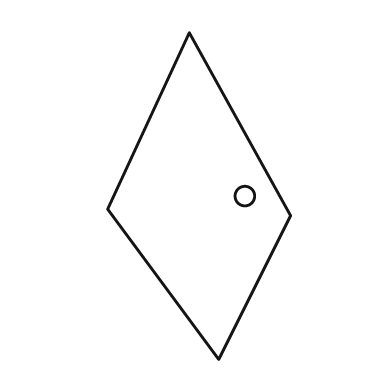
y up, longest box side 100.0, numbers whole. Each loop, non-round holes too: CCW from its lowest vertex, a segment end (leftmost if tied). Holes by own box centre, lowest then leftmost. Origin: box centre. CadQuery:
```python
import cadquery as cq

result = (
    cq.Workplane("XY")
    .moveTo(6.0, -50.0)
    .lineTo(28.0, -6.0)
    .lineTo(-3.0, 50.0)
    .lineTo(-28.0, -4.0)
    .close()
    .moveTo(14.0, 0.0)
    .circle(3.0)
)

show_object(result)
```